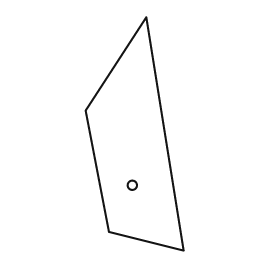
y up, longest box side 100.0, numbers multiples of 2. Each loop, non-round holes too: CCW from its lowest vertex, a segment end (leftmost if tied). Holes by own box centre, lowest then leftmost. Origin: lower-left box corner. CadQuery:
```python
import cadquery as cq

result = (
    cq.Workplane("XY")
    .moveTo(42.0, 0.0)
    .lineTo(26.0, 100.0)
    .lineTo(0.0, 60.0)
    .lineTo(10.0, 8.0)
    .close()
    .moveTo(20.0, 28.0)
    .circle(2.0)
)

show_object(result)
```